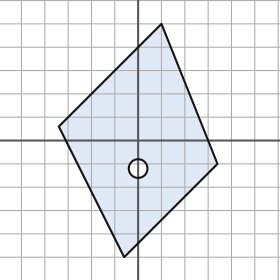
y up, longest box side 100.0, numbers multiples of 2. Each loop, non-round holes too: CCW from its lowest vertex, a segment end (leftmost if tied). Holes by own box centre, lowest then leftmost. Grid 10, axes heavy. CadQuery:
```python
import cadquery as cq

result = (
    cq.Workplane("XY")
    .moveTo(-6.0, -50.0)
    .lineTo(34.0, -10.0)
    .lineTo(10.0, 50.0)
    .lineTo(-34.0, 6.0)
    .close()
    .moveTo(0.0, -12.0)
    .circle(4.0)
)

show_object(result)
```